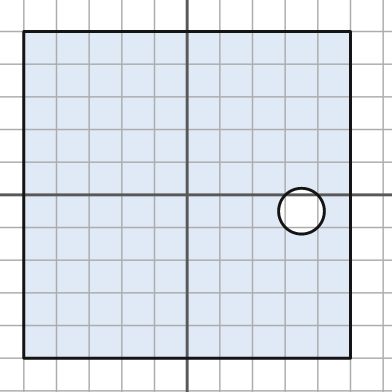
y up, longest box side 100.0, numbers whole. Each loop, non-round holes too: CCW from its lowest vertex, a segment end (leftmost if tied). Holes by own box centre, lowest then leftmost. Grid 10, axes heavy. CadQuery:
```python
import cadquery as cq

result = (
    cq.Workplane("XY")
    .moveTo(-50.0, -50.0)
    .lineTo(50.0, -50.0)
    .lineTo(50.0, 50.0)
    .lineTo(-50.0, 50.0)
    .close()
    .moveTo(35.0, -5.0)
    .circle(7.0)
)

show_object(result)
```